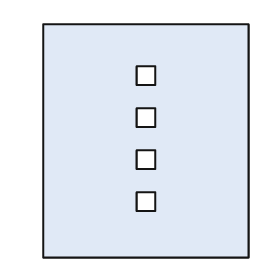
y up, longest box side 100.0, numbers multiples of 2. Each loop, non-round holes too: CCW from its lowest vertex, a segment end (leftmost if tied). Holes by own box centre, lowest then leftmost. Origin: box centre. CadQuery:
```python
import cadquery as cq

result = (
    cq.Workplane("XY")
    .moveTo(-44.0, -50.0)
    .lineTo(44.0, -50.0)
    .lineTo(44.0, 50.0)
    .lineTo(-44.0, 50.0)
    .close()
    .moveTo(-4.0, -30.0)
    .lineTo(4.0, -30.0)
    .lineTo(4.0, -22.0)
    .lineTo(-4.0, -22.0)
    .close()
    .moveTo(-4.0, -12.0)
    .lineTo(4.0, -12.0)
    .lineTo(4.0, -4.0)
    .lineTo(-4.0, -4.0)
    .close()
    .moveTo(-4.0, 6.0)
    .lineTo(4.0, 6.0)
    .lineTo(4.0, 14.0)
    .lineTo(-4.0, 14.0)
    .close()
    .moveTo(-4.0, 24.0)
    .lineTo(4.0, 24.0)
    .lineTo(4.0, 32.0)
    .lineTo(-4.0, 32.0)
    .close()
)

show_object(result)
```